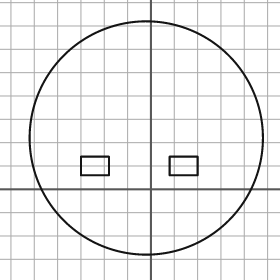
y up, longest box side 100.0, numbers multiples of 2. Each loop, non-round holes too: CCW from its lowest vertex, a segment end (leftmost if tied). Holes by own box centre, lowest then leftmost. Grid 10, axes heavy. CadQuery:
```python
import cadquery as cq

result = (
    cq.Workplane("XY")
    .moveTo(-2.0, 22.0)
    .circle(50.0)
    .moveTo(-30.0, 6.0)
    .lineTo(-18.0, 6.0)
    .lineTo(-18.0, 14.0)
    .lineTo(-30.0, 14.0)
    .close()
    .moveTo(8.0, 6.0)
    .lineTo(20.0, 6.0)
    .lineTo(20.0, 14.0)
    .lineTo(8.0, 14.0)
    .close()
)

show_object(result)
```